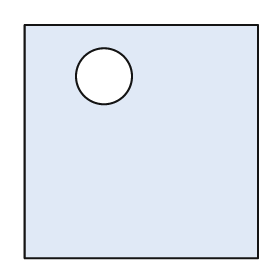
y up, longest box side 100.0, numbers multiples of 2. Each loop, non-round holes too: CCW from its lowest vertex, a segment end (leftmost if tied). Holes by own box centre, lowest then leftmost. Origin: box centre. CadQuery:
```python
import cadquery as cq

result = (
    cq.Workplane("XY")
    .moveTo(-50.0, -50.0)
    .lineTo(50.0, -50.0)
    .lineTo(50.0, 50.0)
    .lineTo(-50.0, 50.0)
    .close()
    .moveTo(-16.0, 28.0)
    .circle(12.0)
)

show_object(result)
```